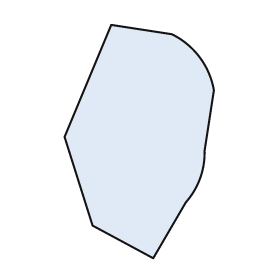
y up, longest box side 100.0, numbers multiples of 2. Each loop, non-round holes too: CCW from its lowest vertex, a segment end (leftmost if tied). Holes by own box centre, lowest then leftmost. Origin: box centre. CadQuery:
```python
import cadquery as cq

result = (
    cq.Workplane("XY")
    .moveTo(6.0, -50.0)
    .lineTo(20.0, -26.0)
    .threePointArc((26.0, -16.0), (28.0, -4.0))
    .lineTo(32.0, 22.0)
    .threePointArc((26.0, 36.0), (14.0, 46.0))
    .lineTo(-12.0, 50.0)
    .lineTo(-32.0, 2.0)
    .lineTo(-20.0, -36.0)
    .close()
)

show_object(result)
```